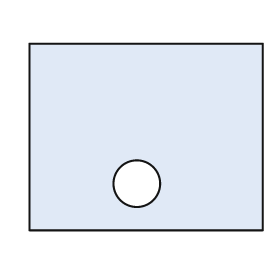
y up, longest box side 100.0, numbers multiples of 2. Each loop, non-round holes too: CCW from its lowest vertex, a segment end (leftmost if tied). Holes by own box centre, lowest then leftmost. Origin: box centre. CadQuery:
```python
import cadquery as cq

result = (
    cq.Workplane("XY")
    .moveTo(-50.0, -40.0)
    .lineTo(50.0, -40.0)
    .lineTo(50.0, 40.0)
    .lineTo(-50.0, 40.0)
    .close()
    .moveTo(-4.0, -20.0)
    .circle(10.0)
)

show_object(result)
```